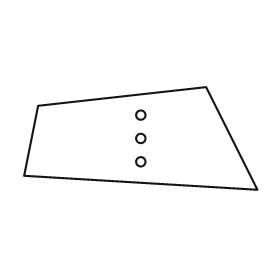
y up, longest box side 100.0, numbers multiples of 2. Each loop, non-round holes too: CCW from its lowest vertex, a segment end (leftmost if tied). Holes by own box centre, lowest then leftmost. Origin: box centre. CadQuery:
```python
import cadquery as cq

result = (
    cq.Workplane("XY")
    .moveTo(50.0, -22.0)
    .lineTo(28.0, 22.0)
    .lineTo(-44.0, 14.0)
    .lineTo(-50.0, -16.0)
    .close()
    .moveTo(0.0, -10.0)
    .circle(2.0)
    .moveTo(0.0, 0.0)
    .circle(2.0)
    .moveTo(0.0, 10.0)
    .circle(2.0)
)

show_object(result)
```